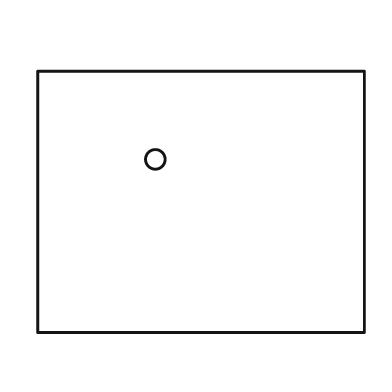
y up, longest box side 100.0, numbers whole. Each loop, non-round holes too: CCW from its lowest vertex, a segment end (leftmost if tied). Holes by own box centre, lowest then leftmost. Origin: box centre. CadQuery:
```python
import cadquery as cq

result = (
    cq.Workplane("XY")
    .moveTo(-50.0, -40.0)
    .lineTo(50.0, -40.0)
    .lineTo(50.0, 40.0)
    .lineTo(-50.0, 40.0)
    .close()
    .moveTo(-14.0, 13.0)
    .circle(3.0)
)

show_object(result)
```